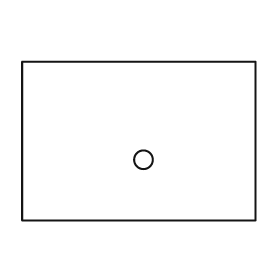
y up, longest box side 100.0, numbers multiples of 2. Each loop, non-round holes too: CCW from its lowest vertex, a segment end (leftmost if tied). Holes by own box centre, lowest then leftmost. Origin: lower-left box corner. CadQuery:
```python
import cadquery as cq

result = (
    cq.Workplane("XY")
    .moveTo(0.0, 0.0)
    .lineTo(100.0, 0.0)
    .lineTo(100.0, 68.0)
    .lineTo(0.0, 68.0)
    .close()
    .moveTo(52.0, 26.0)
    .circle(4.0)
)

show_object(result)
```